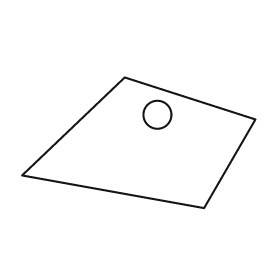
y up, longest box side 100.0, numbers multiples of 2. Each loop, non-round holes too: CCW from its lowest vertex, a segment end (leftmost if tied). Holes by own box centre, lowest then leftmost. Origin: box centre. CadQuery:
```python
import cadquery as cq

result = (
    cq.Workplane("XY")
    .moveTo(28.0, -28.0)
    .lineTo(50.0, 10.0)
    .lineTo(-6.0, 28.0)
    .lineTo(-50.0, -14.0)
    .close()
    .moveTo(8.0, 12.0)
    .circle(6.0)
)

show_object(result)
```